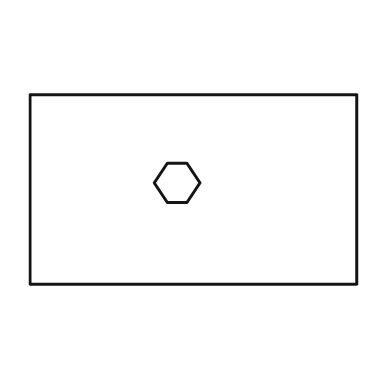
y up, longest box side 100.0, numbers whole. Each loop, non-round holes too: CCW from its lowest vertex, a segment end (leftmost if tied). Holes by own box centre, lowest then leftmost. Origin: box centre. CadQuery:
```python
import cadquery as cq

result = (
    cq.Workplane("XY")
    .moveTo(-50.0, -29.0)
    .lineTo(50.0, -29.0)
    .lineTo(50.0, 29.0)
    .lineTo(-50.0, 29.0)
    .close()
    .moveTo(-8.0, -4.0)
    .lineTo(-2.0, -4.0)
    .lineTo(2.0, 2.0)
    .lineTo(-2.0, 8.0)
    .lineTo(-8.0, 8.0)
    .lineTo(-12.0, 2.0)
    .close()
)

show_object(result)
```